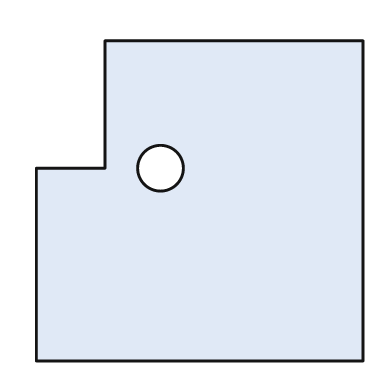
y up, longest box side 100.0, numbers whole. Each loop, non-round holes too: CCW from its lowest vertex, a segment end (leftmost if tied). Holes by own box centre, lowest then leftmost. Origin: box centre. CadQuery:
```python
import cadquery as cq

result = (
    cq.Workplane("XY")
    .moveTo(-50.0, -49.0)
    .lineTo(50.0, -49.0)
    .lineTo(50.0, 49.0)
    .lineTo(-29.0, 49.0)
    .lineTo(-29.0, 10.0)
    .lineTo(-50.0, 10.0)
    .close()
    .moveTo(-12.0, 10.0)
    .circle(7.0)
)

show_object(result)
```